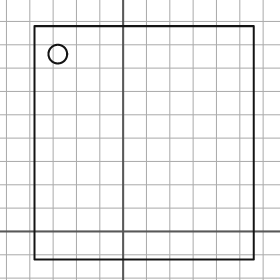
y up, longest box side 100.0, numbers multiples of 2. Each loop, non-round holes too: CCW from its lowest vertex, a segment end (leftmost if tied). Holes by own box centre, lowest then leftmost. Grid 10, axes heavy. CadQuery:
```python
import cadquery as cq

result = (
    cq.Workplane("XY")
    .moveTo(-38.0, -12.0)
    .lineTo(56.0, -12.0)
    .lineTo(56.0, 88.0)
    .lineTo(-38.0, 88.0)
    .close()
    .moveTo(-28.0, 76.0)
    .circle(4.0)
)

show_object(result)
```